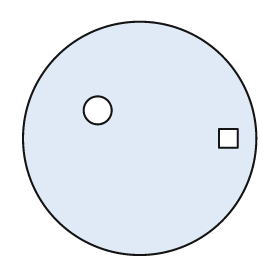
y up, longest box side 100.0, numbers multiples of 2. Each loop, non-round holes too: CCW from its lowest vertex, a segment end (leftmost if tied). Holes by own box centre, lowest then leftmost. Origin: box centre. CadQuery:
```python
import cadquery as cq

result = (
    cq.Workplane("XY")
    .moveTo(0.0, 0.0)
    .circle(50.0)
    .moveTo(34.0, -4.0)
    .lineTo(42.0, -4.0)
    .lineTo(42.0, 4.0)
    .lineTo(34.0, 4.0)
    .close()
    .moveTo(-18.0, 12.0)
    .circle(6.0)
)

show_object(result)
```